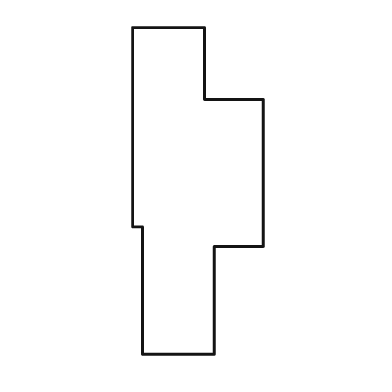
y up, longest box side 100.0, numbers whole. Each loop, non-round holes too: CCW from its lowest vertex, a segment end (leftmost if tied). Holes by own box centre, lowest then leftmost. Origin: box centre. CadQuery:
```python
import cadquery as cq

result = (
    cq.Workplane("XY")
    .moveTo(-17.0, -50.0)
    .lineTo(5.0, -50.0)
    .lineTo(5.0, -17.0)
    .lineTo(20.0, -17.0)
    .lineTo(20.0, 28.0)
    .lineTo(2.0, 28.0)
    .lineTo(2.0, 50.0)
    .lineTo(-20.0, 50.0)
    .lineTo(-20.0, -11.0)
    .lineTo(-17.0, -11.0)
    .close()
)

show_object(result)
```